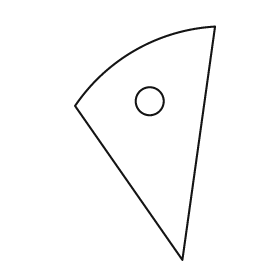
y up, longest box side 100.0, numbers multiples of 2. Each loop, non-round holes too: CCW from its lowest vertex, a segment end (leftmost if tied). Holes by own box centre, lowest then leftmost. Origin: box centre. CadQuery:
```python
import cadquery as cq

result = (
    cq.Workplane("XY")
    .moveTo(16.0, -50.0)
    .lineTo(30.0, 50.0)
    .threePointArc((-4.0, 40.0), (-30.0, 16.0))
    .close()
    .moveTo(2.0, 18.0)
    .circle(6.0)
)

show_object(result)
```